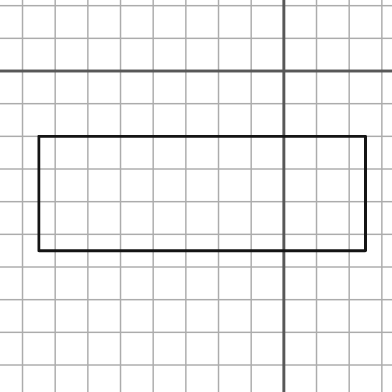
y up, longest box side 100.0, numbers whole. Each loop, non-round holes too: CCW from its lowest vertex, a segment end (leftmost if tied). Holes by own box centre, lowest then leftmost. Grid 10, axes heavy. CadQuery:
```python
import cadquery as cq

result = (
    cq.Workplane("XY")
    .moveTo(-75.0, -55.0)
    .lineTo(25.0, -55.0)
    .lineTo(25.0, -20.0)
    .lineTo(-75.0, -20.0)
    .close()
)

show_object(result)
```